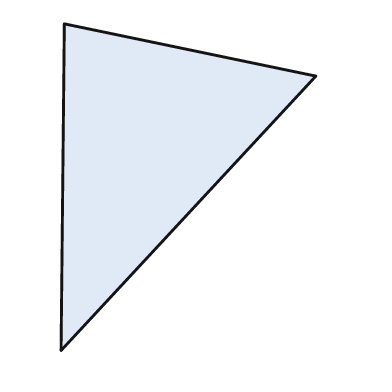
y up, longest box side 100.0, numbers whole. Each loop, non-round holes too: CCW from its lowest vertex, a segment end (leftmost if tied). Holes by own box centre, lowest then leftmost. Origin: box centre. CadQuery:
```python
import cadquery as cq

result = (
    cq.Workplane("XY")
    .moveTo(-39.0, -50.0)
    .lineTo(39.0, 34.0)
    .lineTo(-38.0, 50.0)
    .close()
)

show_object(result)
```